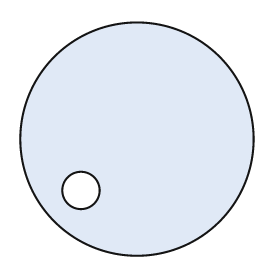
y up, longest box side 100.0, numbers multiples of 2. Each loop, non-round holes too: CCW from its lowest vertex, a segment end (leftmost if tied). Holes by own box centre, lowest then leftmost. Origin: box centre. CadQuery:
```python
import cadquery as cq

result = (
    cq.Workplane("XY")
    .moveTo(0.0, 0.0)
    .circle(50.0)
    .moveTo(-24.0, -22.0)
    .circle(8.0)
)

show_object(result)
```